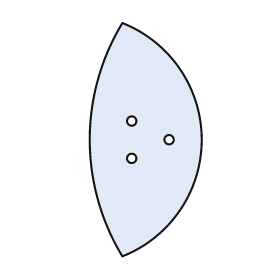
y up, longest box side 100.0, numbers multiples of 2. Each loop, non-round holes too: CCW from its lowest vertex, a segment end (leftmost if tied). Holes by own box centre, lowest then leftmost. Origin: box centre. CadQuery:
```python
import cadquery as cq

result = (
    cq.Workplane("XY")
    .moveTo(-10.0, -50.0)
    .threePointArc((24.0, 0.0), (-10.0, 50.0))
    .threePointArc((-24.0, 0.0), (-10.0, -50.0))
    .close()
    .moveTo(-6.0, -8.0)
    .circle(2.0)
    .moveTo(10.0, 0.0)
    .circle(2.0)
    .moveTo(-6.0, 8.0)
    .circle(2.0)
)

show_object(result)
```